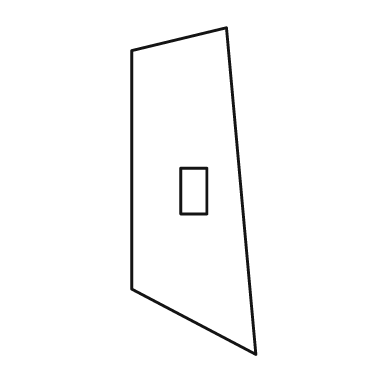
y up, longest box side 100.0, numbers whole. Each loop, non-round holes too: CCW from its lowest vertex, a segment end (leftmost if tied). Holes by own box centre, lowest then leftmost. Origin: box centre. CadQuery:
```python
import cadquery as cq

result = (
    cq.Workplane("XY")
    .moveTo(19.0, -50.0)
    .lineTo(10.0, 50.0)
    .lineTo(-19.0, 43.0)
    .lineTo(-19.0, -30.0)
    .close()
    .moveTo(-4.0, -7.0)
    .lineTo(4.0, -7.0)
    .lineTo(4.0, 7.0)
    .lineTo(-4.0, 7.0)
    .close()
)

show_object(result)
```